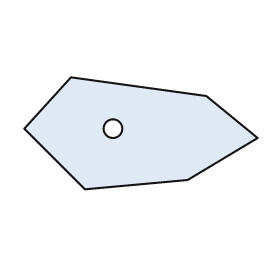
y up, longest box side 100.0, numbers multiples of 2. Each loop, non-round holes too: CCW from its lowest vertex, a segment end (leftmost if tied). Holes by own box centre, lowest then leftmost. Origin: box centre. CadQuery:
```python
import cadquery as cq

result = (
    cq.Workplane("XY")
    .moveTo(-24.0, -24.0)
    .lineTo(20.0, -20.0)
    .lineTo(50.0, -2.0)
    .lineTo(28.0, 16.0)
    .lineTo(-30.0, 24.0)
    .lineTo(-50.0, 2.0)
    .close()
    .moveTo(-12.0, 2.0)
    .circle(4.0)
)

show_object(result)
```